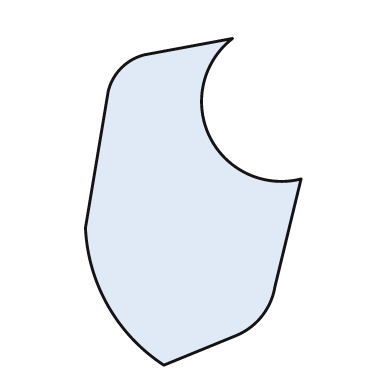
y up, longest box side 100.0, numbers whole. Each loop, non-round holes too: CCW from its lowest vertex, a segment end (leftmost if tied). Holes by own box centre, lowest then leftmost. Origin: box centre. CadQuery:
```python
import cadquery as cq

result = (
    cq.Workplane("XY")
    .moveTo(-9.0, -50.0)
    .lineTo(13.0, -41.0)
    .threePointArc((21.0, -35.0), (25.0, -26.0))
    .lineTo(33.0, 7.0)
    .threePointArc((5.0, 20.0), (12.0, 50.0))
    .lineTo(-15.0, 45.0)
    .threePointArc((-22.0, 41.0), (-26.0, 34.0))
    .lineTo(-33.0, -8.0)
    .threePointArc((-26.0, -32.0), (-9.0, -50.0))
    .close()
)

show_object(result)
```